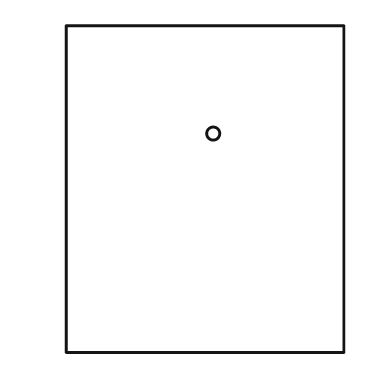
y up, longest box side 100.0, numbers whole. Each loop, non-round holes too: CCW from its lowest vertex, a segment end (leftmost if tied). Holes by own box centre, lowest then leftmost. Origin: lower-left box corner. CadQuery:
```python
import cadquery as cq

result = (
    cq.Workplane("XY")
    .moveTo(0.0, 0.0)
    .lineTo(85.0, 0.0)
    .lineTo(85.0, 100.0)
    .lineTo(0.0, 100.0)
    .close()
    .moveTo(45.0, 67.0)
    .circle(2.0)
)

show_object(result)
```